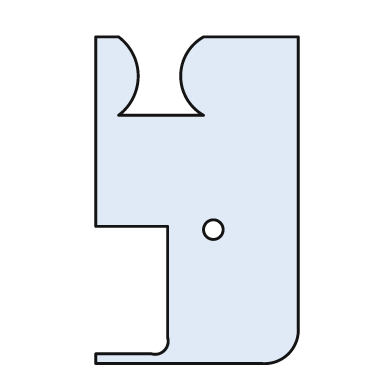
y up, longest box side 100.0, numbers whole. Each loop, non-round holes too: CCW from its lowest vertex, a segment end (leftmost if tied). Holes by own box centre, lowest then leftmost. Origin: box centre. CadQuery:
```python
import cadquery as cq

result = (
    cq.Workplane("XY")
    .moveTo(-31.0, -50.0)
    .lineTo(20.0, -50.0)
    .threePointArc((28.0, -47.0), (31.0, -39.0))
    .lineTo(31.0, 50.0)
    .lineTo(2.0, 50.0)
    .threePointArc((-5.0, 38.0), (2.0, 26.0))
    .lineTo(-24.0, 26.0)
    .threePointArc((-18.0, 38.0), (-24.0, 50.0))
    .lineTo(-31.0, 50.0)
    .lineTo(-31.0, -8.0)
    .lineTo(-9.0, -8.0)
    .lineTo(-9.0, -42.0)
    .threePointArc((-10.0, -46.0), (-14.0, -47.0))
    .lineTo(-31.0, -47.0)
    .close()
    .moveTo(5.0, -9.0)
    .circle(3.0)
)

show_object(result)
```